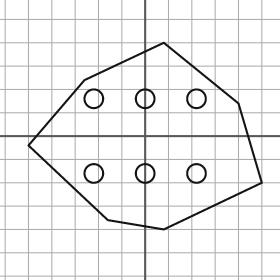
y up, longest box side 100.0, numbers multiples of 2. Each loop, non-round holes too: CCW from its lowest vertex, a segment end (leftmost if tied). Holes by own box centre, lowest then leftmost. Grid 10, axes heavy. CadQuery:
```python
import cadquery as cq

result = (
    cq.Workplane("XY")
    .moveTo(8.0, -40.0)
    .lineTo(50.0, -20.0)
    .lineTo(40.0, 14.0)
    .lineTo(8.0, 40.0)
    .lineTo(-26.0, 24.0)
    .lineTo(-50.0, -4.0)
    .lineTo(-16.0, -36.0)
    .close()
    .moveTo(-22.0, -16.0)
    .circle(4.0)
    .moveTo(0.0, -16.0)
    .circle(4.0)
    .moveTo(22.0, -16.0)
    .circle(4.0)
    .moveTo(-22.0, 16.0)
    .circle(4.0)
    .moveTo(0.0, 16.0)
    .circle(4.0)
    .moveTo(22.0, 16.0)
    .circle(4.0)
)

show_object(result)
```